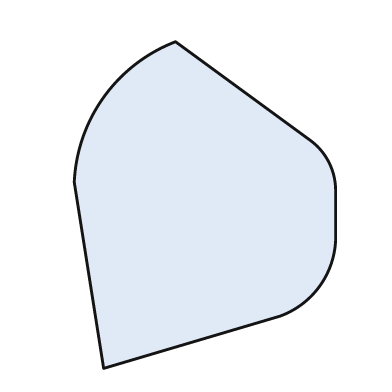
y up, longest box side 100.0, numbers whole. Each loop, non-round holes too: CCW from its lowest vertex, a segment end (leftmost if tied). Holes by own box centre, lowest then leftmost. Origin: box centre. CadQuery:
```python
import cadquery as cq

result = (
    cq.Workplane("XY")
    .moveTo(-31.0, -50.0)
    .lineTo(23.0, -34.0)
    .threePointArc((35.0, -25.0), (40.0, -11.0))
    .lineTo(40.0, 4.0)
    .threePointArc((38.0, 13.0), (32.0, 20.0))
    .lineTo(-9.0, 50.0)
    .threePointArc((-31.0, 33.0), (-40.0, 7.0))
    .close()
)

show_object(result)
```